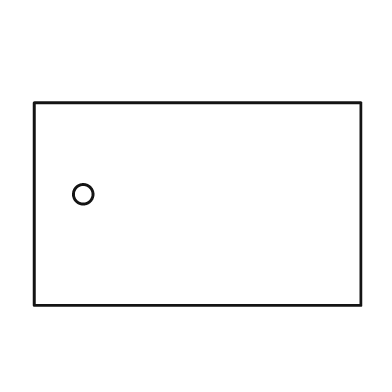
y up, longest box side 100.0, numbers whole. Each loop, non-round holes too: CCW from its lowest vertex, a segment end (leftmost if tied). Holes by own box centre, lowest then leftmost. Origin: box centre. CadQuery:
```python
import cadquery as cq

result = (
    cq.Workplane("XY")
    .moveTo(-50.0, -31.0)
    .lineTo(50.0, -31.0)
    .lineTo(50.0, 31.0)
    .lineTo(-50.0, 31.0)
    .close()
    .moveTo(-35.0, 3.0)
    .circle(3.0)
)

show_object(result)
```